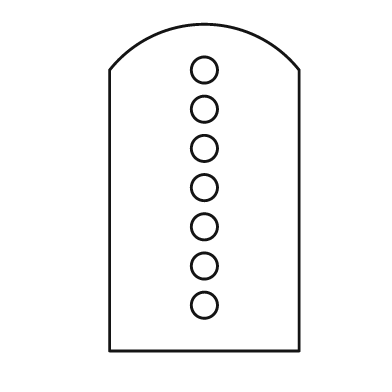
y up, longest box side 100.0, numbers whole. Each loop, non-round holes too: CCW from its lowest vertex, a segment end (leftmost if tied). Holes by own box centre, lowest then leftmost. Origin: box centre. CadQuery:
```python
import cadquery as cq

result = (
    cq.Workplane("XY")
    .moveTo(-29.0, -50.0)
    .lineTo(29.0, -50.0)
    .lineTo(29.0, 36.0)
    .threePointArc((0.0, 50.0), (-29.0, 36.0))
    .close()
    .moveTo(0.0, -36.0)
    .circle(4.0)
    .moveTo(0.0, -24.0)
    .circle(4.0)
    .moveTo(0.0, -12.0)
    .circle(4.0)
    .moveTo(0.0, 0.0)
    .circle(4.0)
    .moveTo(0.0, 12.0)
    .circle(4.0)
    .moveTo(0.0, 24.0)
    .circle(4.0)
    .moveTo(0.0, 36.0)
    .circle(4.0)
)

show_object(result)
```